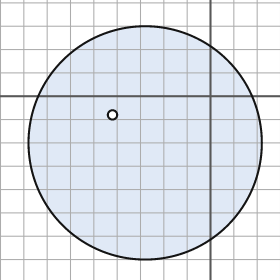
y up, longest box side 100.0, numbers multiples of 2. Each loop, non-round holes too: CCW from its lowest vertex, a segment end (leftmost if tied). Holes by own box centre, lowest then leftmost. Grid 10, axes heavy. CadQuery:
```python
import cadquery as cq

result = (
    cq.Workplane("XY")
    .moveTo(-28.0, -20.0)
    .circle(50.0)
    .moveTo(-42.0, -8.0)
    .circle(2.0)
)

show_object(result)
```